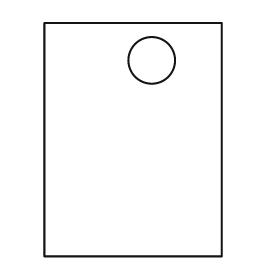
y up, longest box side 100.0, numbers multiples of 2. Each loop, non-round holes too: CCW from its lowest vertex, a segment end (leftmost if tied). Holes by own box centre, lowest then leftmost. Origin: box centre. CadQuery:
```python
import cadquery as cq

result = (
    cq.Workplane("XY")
    .moveTo(-38.0, -50.0)
    .lineTo(38.0, -50.0)
    .lineTo(38.0, 50.0)
    .lineTo(-38.0, 50.0)
    .close()
    .moveTo(8.0, 34.0)
    .circle(10.0)
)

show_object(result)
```